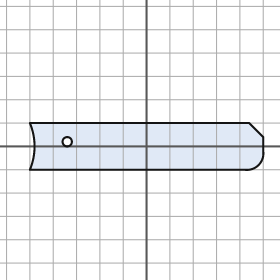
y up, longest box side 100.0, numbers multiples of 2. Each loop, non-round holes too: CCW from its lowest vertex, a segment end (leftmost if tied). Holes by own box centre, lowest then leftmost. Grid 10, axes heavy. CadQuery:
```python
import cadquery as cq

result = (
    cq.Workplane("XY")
    .moveTo(-50.0, -10.0)
    .lineTo(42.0, -10.0)
    .threePointArc((48.0, -8.0), (50.0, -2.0))
    .lineTo(50.0, 4.0)
    .lineTo(44.0, 10.0)
    .lineTo(-50.0, 10.0)
    .threePointArc((-48.0, 0.0), (-50.0, -10.0))
    .close()
    .moveTo(-34.0, 2.0)
    .circle(2.0)
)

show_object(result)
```